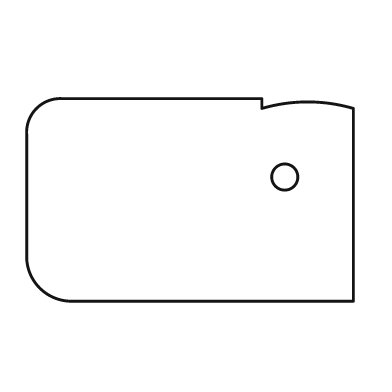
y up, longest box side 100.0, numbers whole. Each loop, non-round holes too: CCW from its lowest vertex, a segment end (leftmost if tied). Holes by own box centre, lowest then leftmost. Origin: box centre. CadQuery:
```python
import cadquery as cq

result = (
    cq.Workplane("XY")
    .moveTo(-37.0, -31.0)
    .lineTo(50.0, -31.0)
    .lineTo(50.0, 28.0)
    .threePointArc((36.0, 30.0), (22.0, 28.0))
    .lineTo(22.0, 31.0)
    .lineTo(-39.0, 31.0)
    .threePointArc((-47.0, 28.0), (-50.0, 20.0))
    .lineTo(-50.0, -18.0)
    .threePointArc((-46.0, -27.0), (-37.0, -31.0))
    .close()
    .moveTo(29.0, 7.0)
    .circle(4.0)
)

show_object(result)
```